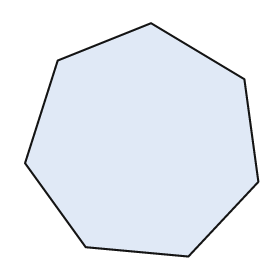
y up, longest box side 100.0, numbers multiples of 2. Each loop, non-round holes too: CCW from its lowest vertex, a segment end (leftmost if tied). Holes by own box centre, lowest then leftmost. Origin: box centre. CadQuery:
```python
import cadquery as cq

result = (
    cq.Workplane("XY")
    .moveTo(20.0, -50.0)
    .lineTo(50.0, -18.0)
    .lineTo(44.0, 26.0)
    .lineTo(4.0, 50.0)
    .lineTo(-36.0, 34.0)
    .lineTo(-50.0, -10.0)
    .lineTo(-24.0, -46.0)
    .close()
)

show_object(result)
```